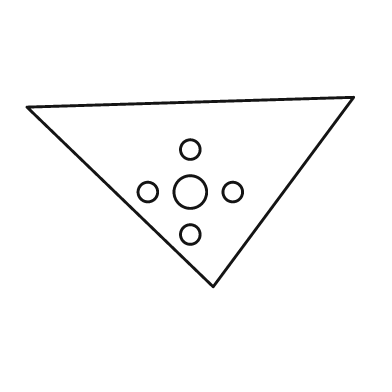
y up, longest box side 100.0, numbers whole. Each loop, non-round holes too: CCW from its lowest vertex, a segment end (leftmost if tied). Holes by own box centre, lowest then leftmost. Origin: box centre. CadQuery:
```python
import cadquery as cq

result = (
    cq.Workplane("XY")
    .moveTo(7.0, -29.0)
    .lineTo(50.0, 29.0)
    .lineTo(-50.0, 26.0)
    .close()
    .moveTo(0.0, -13.0)
    .circle(3.0)
    .moveTo(-13.0, 0.0)
    .circle(3.0)
    .moveTo(0.0, 0.0)
    .circle(5.0)
    .moveTo(13.0, 0.0)
    .circle(3.0)
    .moveTo(0.0, 13.0)
    .circle(3.0)
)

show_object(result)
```